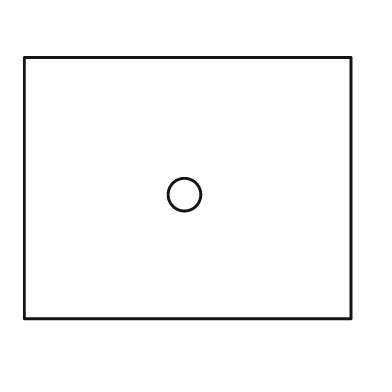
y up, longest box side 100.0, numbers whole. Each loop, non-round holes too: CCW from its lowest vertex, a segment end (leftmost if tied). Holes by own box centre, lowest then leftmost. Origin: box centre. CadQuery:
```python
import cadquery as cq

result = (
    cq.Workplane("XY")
    .moveTo(-50.0, -40.0)
    .lineTo(50.0, -40.0)
    .lineTo(50.0, 40.0)
    .lineTo(-50.0, 40.0)
    .close()
    .moveTo(-1.0, -2.0)
    .circle(5.0)
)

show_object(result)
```